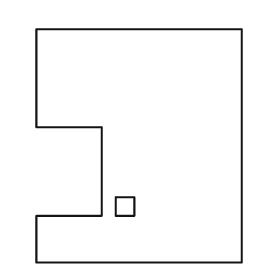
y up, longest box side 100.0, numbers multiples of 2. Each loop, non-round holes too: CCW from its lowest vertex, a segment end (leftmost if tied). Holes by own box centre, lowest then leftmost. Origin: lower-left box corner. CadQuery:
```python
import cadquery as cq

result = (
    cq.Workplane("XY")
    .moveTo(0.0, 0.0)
    .lineTo(88.0, 0.0)
    .lineTo(88.0, 100.0)
    .lineTo(0.0, 100.0)
    .lineTo(0.0, 58.0)
    .lineTo(28.0, 58.0)
    .lineTo(28.0, 20.0)
    .lineTo(0.0, 20.0)
    .close()
    .moveTo(34.0, 20.0)
    .lineTo(42.0, 20.0)
    .lineTo(42.0, 28.0)
    .lineTo(34.0, 28.0)
    .close()
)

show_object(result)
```